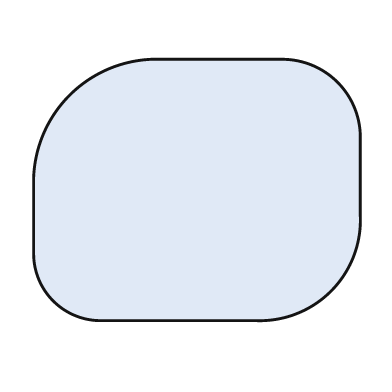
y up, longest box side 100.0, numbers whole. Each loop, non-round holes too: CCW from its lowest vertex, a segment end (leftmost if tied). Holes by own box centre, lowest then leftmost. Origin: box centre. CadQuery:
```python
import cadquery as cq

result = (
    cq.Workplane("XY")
    .moveTo(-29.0, -40.0)
    .lineTo(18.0, -40.0)
    .threePointArc((41.0, -31.0), (50.0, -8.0))
    .lineTo(50.0, 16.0)
    .threePointArc((43.0, 33.0), (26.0, 40.0))
    .lineTo(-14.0, 40.0)
    .threePointArc((-39.0, 29.0), (-50.0, 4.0))
    .lineTo(-50.0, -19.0)
    .threePointArc((-44.0, -34.0), (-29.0, -40.0))
    .close()
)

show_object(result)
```